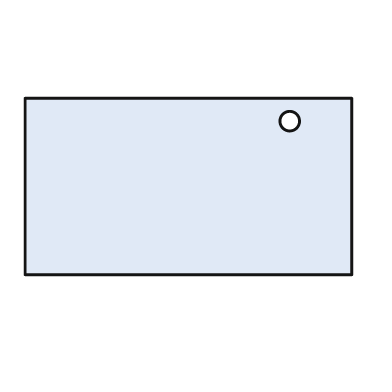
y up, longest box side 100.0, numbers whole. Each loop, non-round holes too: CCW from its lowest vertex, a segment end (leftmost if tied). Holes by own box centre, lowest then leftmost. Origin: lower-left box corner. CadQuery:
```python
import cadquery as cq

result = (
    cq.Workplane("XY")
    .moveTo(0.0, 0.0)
    .lineTo(100.0, 0.0)
    .lineTo(100.0, 54.0)
    .lineTo(0.0, 54.0)
    .close()
    .moveTo(81.0, 47.0)
    .circle(3.0)
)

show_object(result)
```